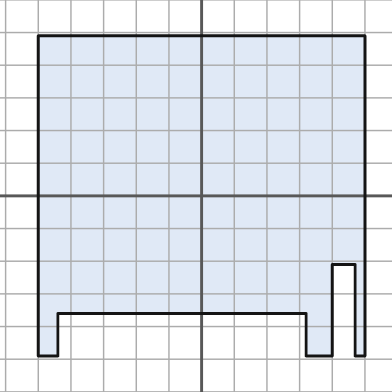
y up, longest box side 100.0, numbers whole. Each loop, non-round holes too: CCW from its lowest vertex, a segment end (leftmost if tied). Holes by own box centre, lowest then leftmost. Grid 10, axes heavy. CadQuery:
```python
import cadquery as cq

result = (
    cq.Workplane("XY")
    .moveTo(-50.0, -49.0)
    .lineTo(-44.0, -49.0)
    .lineTo(-44.0, -36.0)
    .lineTo(32.0, -36.0)
    .lineTo(32.0, -49.0)
    .lineTo(40.0, -49.0)
    .lineTo(40.0, -21.0)
    .lineTo(47.0, -21.0)
    .lineTo(47.0, -49.0)
    .lineTo(50.0, -49.0)
    .lineTo(50.0, 49.0)
    .lineTo(-50.0, 49.0)
    .close()
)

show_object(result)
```